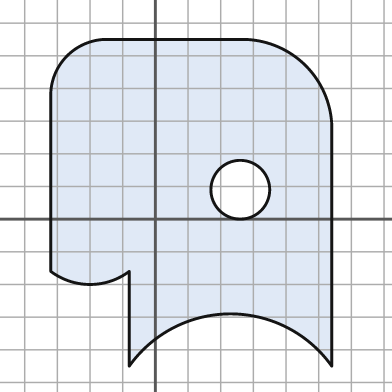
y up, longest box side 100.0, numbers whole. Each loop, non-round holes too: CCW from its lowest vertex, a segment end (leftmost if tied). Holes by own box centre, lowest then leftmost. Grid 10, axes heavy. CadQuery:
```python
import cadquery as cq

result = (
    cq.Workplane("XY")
    .moveTo(-8.0, -45.0)
    .threePointArc((23.0, -29.0), (54.0, -45.0))
    .lineTo(54.0, 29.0)
    .threePointArc((46.0, 47.0), (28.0, 55.0))
    .lineTo(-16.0, 55.0)
    .threePointArc((-27.0, 50.0), (-32.0, 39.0))
    .lineTo(-32.0, -16.0)
    .threePointArc((-20.0, -20.0), (-8.0, -16.0))
    .close()
    .moveTo(26.0, 9.0)
    .circle(9.0)
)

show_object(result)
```